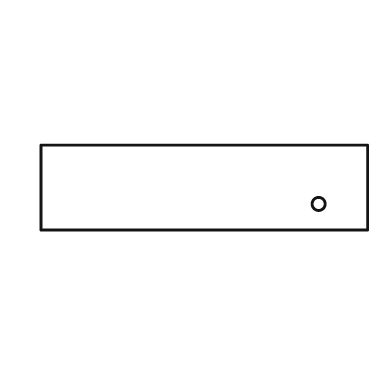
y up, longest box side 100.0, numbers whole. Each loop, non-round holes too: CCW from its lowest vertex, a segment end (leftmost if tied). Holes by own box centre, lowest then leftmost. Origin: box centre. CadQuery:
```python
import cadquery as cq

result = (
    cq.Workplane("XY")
    .moveTo(-50.0, -13.0)
    .lineTo(50.0, -13.0)
    .lineTo(50.0, 13.0)
    .lineTo(-50.0, 13.0)
    .close()
    .moveTo(35.0, -5.0)
    .circle(2.0)
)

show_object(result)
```